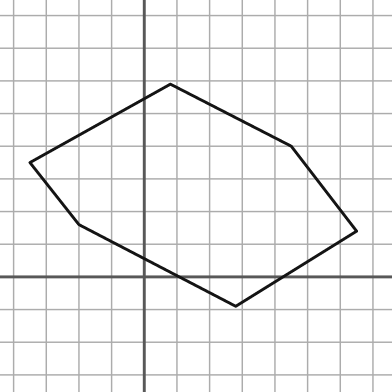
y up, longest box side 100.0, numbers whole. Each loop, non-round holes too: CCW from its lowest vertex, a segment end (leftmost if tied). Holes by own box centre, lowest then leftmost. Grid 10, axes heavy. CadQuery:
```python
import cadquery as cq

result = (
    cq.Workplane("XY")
    .moveTo(28.0, -9.0)
    .lineTo(65.0, 14.0)
    .lineTo(45.0, 40.0)
    .lineTo(8.0, 59.0)
    .lineTo(-35.0, 35.0)
    .lineTo(-20.0, 16.0)
    .close()
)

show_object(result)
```